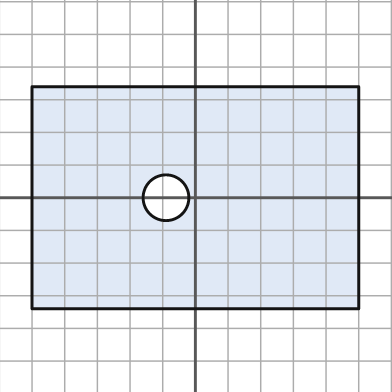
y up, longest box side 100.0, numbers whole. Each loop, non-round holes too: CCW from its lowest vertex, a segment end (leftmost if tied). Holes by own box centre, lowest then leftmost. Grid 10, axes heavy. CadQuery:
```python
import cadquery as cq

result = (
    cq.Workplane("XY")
    .moveTo(-50.0, -34.0)
    .lineTo(50.0, -34.0)
    .lineTo(50.0, 34.0)
    .lineTo(-50.0, 34.0)
    .close()
    .moveTo(-9.0, 0.0)
    .circle(7.0)
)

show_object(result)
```